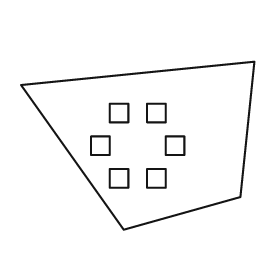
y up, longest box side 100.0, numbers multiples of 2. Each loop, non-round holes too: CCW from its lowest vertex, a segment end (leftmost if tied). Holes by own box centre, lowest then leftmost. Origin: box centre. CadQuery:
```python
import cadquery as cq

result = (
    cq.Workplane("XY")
    .moveTo(-6.0, -36.0)
    .lineTo(44.0, -22.0)
    .lineTo(50.0, 36.0)
    .lineTo(-50.0, 26.0)
    .close()
    .moveTo(-12.0, -18.0)
    .lineTo(-4.0, -18.0)
    .lineTo(-4.0, -10.0)
    .lineTo(-12.0, -10.0)
    .close()
    .moveTo(4.0, -18.0)
    .lineTo(12.0, -18.0)
    .lineTo(12.0, -10.0)
    .lineTo(4.0, -10.0)
    .close()
    .moveTo(-20.0, -4.0)
    .lineTo(-12.0, -4.0)
    .lineTo(-12.0, 4.0)
    .lineTo(-20.0, 4.0)
    .close()
    .moveTo(12.0, -4.0)
    .lineTo(20.0, -4.0)
    .lineTo(20.0, 4.0)
    .lineTo(12.0, 4.0)
    .close()
    .moveTo(-12.0, 10.0)
    .lineTo(-4.0, 10.0)
    .lineTo(-4.0, 18.0)
    .lineTo(-12.0, 18.0)
    .close()
    .moveTo(4.0, 10.0)
    .lineTo(12.0, 10.0)
    .lineTo(12.0, 18.0)
    .lineTo(4.0, 18.0)
    .close()
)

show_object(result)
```